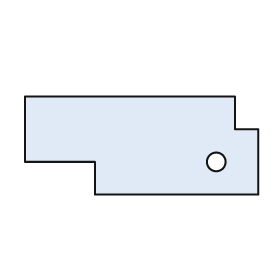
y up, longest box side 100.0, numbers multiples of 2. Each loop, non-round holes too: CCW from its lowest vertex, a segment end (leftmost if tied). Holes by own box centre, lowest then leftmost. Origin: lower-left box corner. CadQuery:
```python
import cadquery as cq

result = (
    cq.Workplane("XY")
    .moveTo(30.0, 0.0)
    .lineTo(100.0, 0.0)
    .lineTo(100.0, 28.0)
    .lineTo(90.0, 28.0)
    .lineTo(90.0, 42.0)
    .lineTo(0.0, 42.0)
    .lineTo(0.0, 14.0)
    .lineTo(30.0, 14.0)
    .close()
    .moveTo(82.0, 14.0)
    .circle(4.0)
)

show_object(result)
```